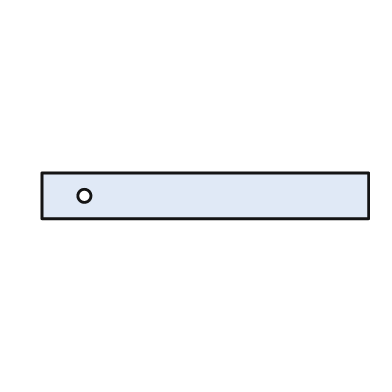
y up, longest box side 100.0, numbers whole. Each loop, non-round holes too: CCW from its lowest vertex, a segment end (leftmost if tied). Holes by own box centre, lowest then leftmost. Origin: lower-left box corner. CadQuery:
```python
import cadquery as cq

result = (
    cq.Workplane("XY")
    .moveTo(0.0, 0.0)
    .lineTo(100.0, 0.0)
    .lineTo(100.0, 14.0)
    .lineTo(0.0, 14.0)
    .close()
    .moveTo(13.0, 7.0)
    .circle(2.0)
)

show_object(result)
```